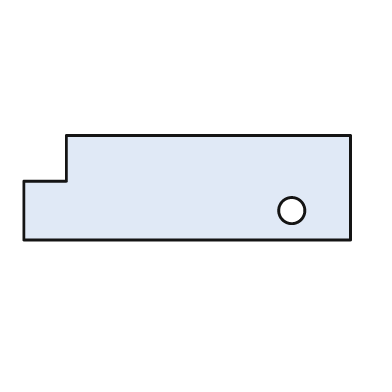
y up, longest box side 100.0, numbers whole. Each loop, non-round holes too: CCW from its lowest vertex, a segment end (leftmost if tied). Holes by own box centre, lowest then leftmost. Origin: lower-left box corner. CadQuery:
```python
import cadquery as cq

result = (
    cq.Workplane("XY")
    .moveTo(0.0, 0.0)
    .lineTo(100.0, 0.0)
    .lineTo(100.0, 32.0)
    .lineTo(13.0, 32.0)
    .lineTo(13.0, 18.0)
    .lineTo(0.0, 18.0)
    .close()
    .moveTo(82.0, 9.0)
    .circle(4.0)
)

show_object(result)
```